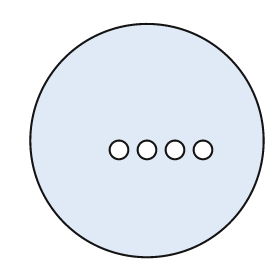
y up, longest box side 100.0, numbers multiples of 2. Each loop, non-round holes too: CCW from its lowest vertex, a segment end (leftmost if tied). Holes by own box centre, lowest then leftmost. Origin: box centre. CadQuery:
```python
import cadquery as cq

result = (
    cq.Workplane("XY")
    .moveTo(0.0, 0.0)
    .circle(50.0)
    .moveTo(-12.0, -4.0)
    .circle(4.0)
    .moveTo(0.0, -4.0)
    .circle(4.0)
    .moveTo(12.0, -4.0)
    .circle(4.0)
    .moveTo(24.0, -4.0)
    .circle(4.0)
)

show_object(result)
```